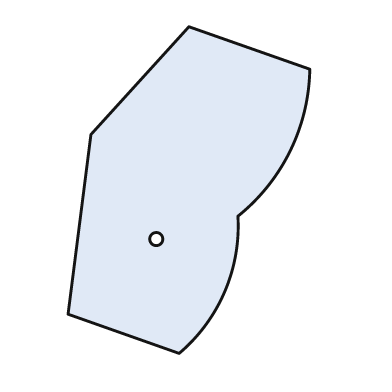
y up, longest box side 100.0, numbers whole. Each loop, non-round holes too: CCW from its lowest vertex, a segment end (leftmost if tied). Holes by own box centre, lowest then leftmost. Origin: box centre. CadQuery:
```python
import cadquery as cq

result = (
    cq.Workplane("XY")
    .moveTo(-3.0, -50.0)
    .threePointArc((11.0, -31.0), (15.0, -8.0))
    .threePointArc((31.0, 12.0), (37.0, 37.0))
    .lineTo(0.0, 50.0)
    .lineTo(-30.0, 17.0)
    .lineTo(-37.0, -38.0)
    .close()
    .moveTo(-10.0, -15.0)
    .circle(2.0)
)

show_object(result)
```